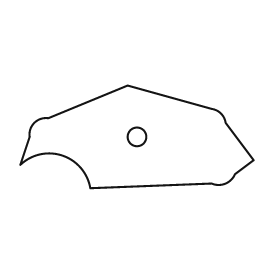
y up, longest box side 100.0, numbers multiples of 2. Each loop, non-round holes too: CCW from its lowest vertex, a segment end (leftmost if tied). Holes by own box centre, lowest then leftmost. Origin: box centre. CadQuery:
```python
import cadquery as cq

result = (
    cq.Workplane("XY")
    .moveTo(-20.0, -22.0)
    .lineTo(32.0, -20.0)
    .threePointArc((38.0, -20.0), (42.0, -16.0))
    .lineTo(50.0, -10.0)
    .lineTo(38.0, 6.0)
    .threePointArc((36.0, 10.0), (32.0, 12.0))
    .lineTo(-4.0, 22.0)
    .lineTo(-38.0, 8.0)
    .threePointArc((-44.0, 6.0), (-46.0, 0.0))
    .lineTo(-50.0, -12.0)
    .threePointArc((-32.0, -8.0), (-20.0, -22.0))
    .close()
    .moveTo(0.0, 0.0)
    .circle(4.0)
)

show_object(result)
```